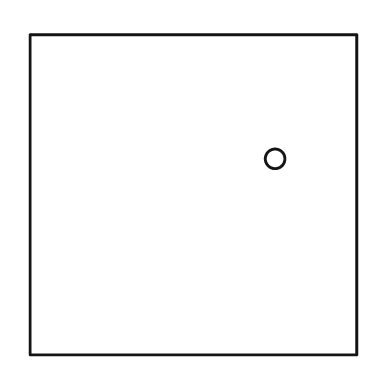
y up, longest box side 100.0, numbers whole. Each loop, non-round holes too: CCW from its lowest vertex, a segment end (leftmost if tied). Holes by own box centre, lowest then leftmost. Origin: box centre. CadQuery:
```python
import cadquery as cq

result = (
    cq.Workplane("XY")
    .moveTo(-50.0, -49.0)
    .lineTo(50.0, -49.0)
    .lineTo(50.0, 49.0)
    .lineTo(-50.0, 49.0)
    .close()
    .moveTo(25.0, 11.0)
    .circle(3.0)
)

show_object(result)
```